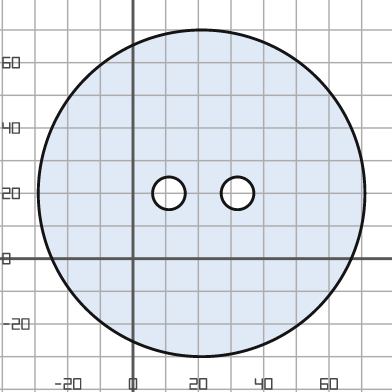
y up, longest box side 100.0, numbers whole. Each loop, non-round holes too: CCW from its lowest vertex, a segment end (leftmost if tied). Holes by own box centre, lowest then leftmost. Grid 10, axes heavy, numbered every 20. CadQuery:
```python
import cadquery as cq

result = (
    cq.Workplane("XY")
    .moveTo(21.0, 20.0)
    .circle(50.0)
    .moveTo(11.0, 20.0)
    .circle(5.0)
    .moveTo(32.0, 20.0)
    .circle(5.0)
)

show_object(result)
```